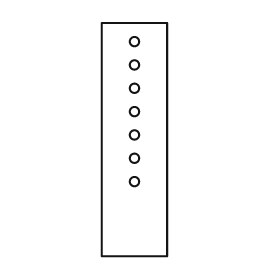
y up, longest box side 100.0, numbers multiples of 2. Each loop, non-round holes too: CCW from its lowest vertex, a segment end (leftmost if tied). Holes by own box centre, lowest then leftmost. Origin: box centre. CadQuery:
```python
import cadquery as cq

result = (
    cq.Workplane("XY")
    .moveTo(-14.0, -50.0)
    .lineTo(14.0, -50.0)
    .lineTo(14.0, 50.0)
    .lineTo(-14.0, 50.0)
    .close()
    .moveTo(0.0, -18.0)
    .circle(2.0)
    .moveTo(0.0, -8.0)
    .circle(2.0)
    .moveTo(0.0, 2.0)
    .circle(2.0)
    .moveTo(0.0, 12.0)
    .circle(2.0)
    .moveTo(0.0, 22.0)
    .circle(2.0)
    .moveTo(0.0, 32.0)
    .circle(2.0)
    .moveTo(0.0, 42.0)
    .circle(2.0)
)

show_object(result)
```